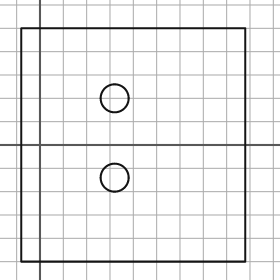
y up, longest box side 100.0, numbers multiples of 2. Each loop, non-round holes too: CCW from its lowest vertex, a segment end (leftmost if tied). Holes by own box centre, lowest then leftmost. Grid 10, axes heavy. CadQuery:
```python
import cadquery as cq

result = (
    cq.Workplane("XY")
    .moveTo(-8.0, -50.0)
    .lineTo(88.0, -50.0)
    .lineTo(88.0, 50.0)
    .lineTo(-8.0, 50.0)
    .close()
    .moveTo(32.0, -14.0)
    .circle(6.0)
    .moveTo(32.0, 20.0)
    .circle(6.0)
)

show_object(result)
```